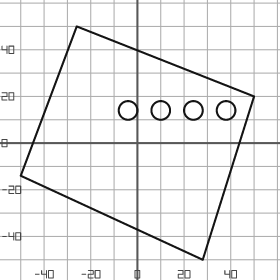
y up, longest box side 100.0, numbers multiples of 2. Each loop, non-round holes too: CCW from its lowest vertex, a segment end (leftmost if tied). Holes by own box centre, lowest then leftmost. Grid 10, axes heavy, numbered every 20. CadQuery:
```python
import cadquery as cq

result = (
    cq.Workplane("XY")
    .moveTo(28.0, -50.0)
    .lineTo(50.0, 20.0)
    .lineTo(-26.0, 50.0)
    .lineTo(-50.0, -14.0)
    .close()
    .moveTo(-4.0, 14.0)
    .circle(4.0)
    .moveTo(10.0, 14.0)
    .circle(4.0)
    .moveTo(24.0, 14.0)
    .circle(4.0)
    .moveTo(38.0, 14.0)
    .circle(4.0)
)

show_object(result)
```